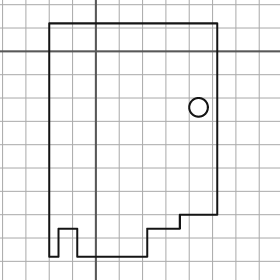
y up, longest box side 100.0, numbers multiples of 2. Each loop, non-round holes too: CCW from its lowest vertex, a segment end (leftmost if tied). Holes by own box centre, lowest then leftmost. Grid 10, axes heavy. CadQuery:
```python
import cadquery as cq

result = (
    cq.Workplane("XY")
    .moveTo(-20.0, -88.0)
    .lineTo(-16.0, -88.0)
    .lineTo(-16.0, -76.0)
    .lineTo(-8.0, -76.0)
    .lineTo(-8.0, -88.0)
    .lineTo(22.0, -88.0)
    .lineTo(22.0, -76.0)
    .lineTo(36.0, -76.0)
    .lineTo(36.0, -70.0)
    .lineTo(52.0, -70.0)
    .lineTo(52.0, 12.0)
    .lineTo(-20.0, 12.0)
    .close()
    .moveTo(44.0, -24.0)
    .circle(4.0)
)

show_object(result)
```